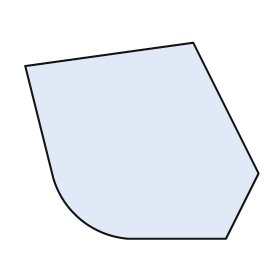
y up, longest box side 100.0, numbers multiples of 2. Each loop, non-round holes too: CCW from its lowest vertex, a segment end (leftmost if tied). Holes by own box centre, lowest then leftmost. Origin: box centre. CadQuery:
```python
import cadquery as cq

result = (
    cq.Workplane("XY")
    .moveTo(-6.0, -42.0)
    .lineTo(36.0, -42.0)
    .lineTo(50.0, -14.0)
    .lineTo(22.0, 42.0)
    .lineTo(-50.0, 32.0)
    .lineTo(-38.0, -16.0)
    .threePointArc((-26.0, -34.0), (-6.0, -42.0))
    .close()
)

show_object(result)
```